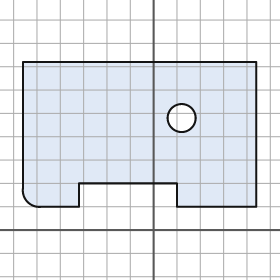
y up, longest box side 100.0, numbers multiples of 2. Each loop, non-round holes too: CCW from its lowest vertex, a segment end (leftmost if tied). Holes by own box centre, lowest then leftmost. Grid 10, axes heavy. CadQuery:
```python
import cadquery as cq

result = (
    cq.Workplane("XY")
    .moveTo(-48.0, 10.0)
    .lineTo(-32.0, 10.0)
    .lineTo(-32.0, 20.0)
    .lineTo(10.0, 20.0)
    .lineTo(10.0, 10.0)
    .lineTo(44.0, 10.0)
    .lineTo(44.0, 72.0)
    .lineTo(-56.0, 72.0)
    .lineTo(-56.0, 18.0)
    .threePointArc((-54.0, 12.0), (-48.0, 10.0))
    .close()
    .moveTo(12.0, 48.0)
    .circle(6.0)
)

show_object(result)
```